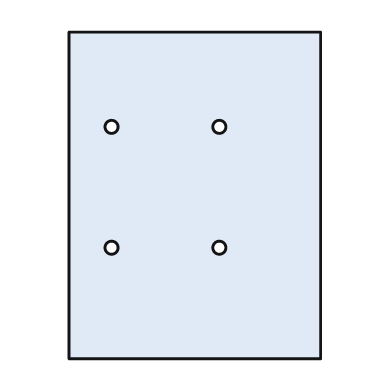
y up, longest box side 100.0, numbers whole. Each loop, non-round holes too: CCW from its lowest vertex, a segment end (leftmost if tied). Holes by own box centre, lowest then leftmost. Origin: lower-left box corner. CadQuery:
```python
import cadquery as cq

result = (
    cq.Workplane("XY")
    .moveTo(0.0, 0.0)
    .lineTo(77.0, 0.0)
    .lineTo(77.0, 100.0)
    .lineTo(0.0, 100.0)
    .close()
    .moveTo(13.0, 34.0)
    .circle(2.0)
    .moveTo(46.0, 34.0)
    .circle(2.0)
    .moveTo(13.0, 71.0)
    .circle(2.0)
    .moveTo(46.0, 71.0)
    .circle(2.0)
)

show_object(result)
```